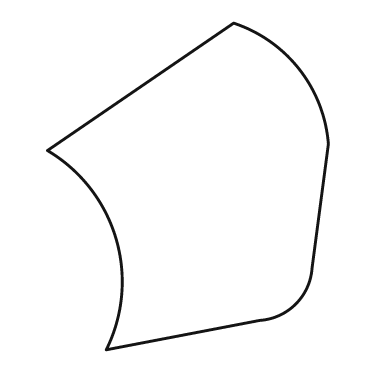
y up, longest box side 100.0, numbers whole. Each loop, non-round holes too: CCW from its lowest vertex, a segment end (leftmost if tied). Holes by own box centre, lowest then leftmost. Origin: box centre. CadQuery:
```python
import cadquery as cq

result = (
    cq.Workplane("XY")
    .moveTo(-25.0, -50.0)
    .lineTo(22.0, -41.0)
    .threePointArc((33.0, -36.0), (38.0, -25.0))
    .lineTo(43.0, 13.0)
    .threePointArc((34.0, 36.0), (14.0, 50.0))
    .lineTo(-43.0, 11.0)
    .threePointArc((-22.0, -16.0), (-25.0, -50.0))
    .close()
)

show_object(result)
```